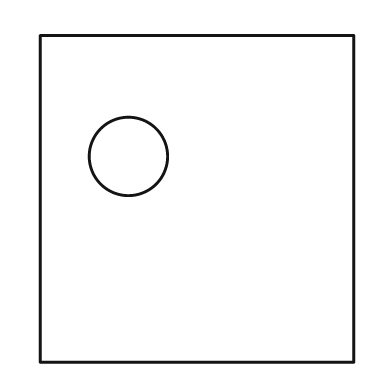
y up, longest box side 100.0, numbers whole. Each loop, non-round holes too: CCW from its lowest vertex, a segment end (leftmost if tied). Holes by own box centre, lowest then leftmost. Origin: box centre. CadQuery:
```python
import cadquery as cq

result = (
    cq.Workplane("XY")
    .moveTo(-48.0, -50.0)
    .lineTo(48.0, -50.0)
    .lineTo(48.0, 50.0)
    .lineTo(-48.0, 50.0)
    .close()
    .moveTo(-21.0, 13.0)
    .circle(12.0)
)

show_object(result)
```